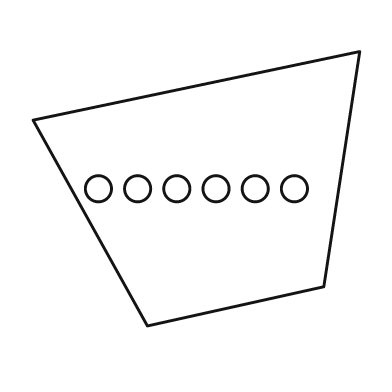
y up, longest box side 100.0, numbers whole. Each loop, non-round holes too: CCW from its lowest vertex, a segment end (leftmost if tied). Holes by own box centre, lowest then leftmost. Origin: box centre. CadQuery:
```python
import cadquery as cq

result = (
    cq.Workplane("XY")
    .moveTo(-15.0, -42.0)
    .lineTo(39.0, -30.0)
    .lineTo(50.0, 42.0)
    .lineTo(-50.0, 21.0)
    .close()
    .moveTo(-30.0, 0.0)
    .circle(4.0)
    .moveTo(-18.0, 0.0)
    .circle(4.0)
    .moveTo(-6.0, 0.0)
    .circle(4.0)
    .moveTo(6.0, 0.0)
    .circle(4.0)
    .moveTo(18.0, 0.0)
    .circle(4.0)
    .moveTo(30.0, 0.0)
    .circle(4.0)
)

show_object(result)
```